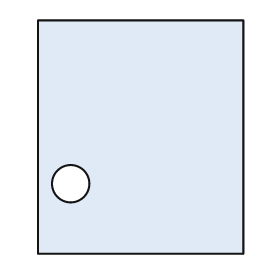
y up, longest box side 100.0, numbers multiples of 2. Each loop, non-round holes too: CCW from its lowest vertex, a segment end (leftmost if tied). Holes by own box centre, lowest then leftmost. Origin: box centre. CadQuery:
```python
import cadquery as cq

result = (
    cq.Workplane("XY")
    .moveTo(-44.0, -50.0)
    .lineTo(44.0, -50.0)
    .lineTo(44.0, 50.0)
    .lineTo(-44.0, 50.0)
    .close()
    .moveTo(-30.0, -20.0)
    .circle(8.0)
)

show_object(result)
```